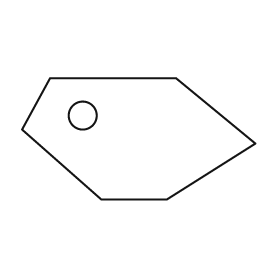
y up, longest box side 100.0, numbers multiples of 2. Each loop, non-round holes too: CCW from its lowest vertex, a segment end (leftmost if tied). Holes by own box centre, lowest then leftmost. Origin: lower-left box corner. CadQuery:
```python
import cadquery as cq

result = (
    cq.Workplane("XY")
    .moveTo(34.0, 0.0)
    .lineTo(62.0, 0.0)
    .lineTo(100.0, 24.0)
    .lineTo(66.0, 52.0)
    .lineTo(12.0, 52.0)
    .lineTo(0.0, 30.0)
    .close()
    .moveTo(26.0, 36.0)
    .circle(6.0)
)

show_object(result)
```